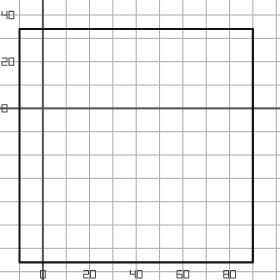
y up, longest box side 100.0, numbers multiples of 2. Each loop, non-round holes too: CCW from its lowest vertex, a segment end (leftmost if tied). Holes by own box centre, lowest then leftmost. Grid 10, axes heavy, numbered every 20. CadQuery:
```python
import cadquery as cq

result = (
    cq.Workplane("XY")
    .moveTo(-10.0, -66.0)
    .lineTo(90.0, -66.0)
    .lineTo(90.0, 34.0)
    .lineTo(-10.0, 34.0)
    .close()
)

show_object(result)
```